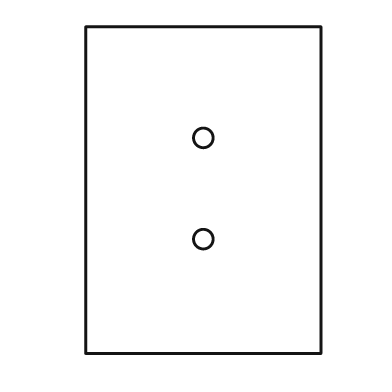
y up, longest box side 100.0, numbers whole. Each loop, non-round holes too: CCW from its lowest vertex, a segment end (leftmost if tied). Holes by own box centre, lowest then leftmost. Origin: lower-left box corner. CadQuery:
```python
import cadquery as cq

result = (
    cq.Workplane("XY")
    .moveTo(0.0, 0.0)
    .lineTo(72.0, 0.0)
    .lineTo(72.0, 100.0)
    .lineTo(0.0, 100.0)
    .close()
    .moveTo(36.0, 35.0)
    .circle(3.0)
    .moveTo(36.0, 66.0)
    .circle(3.0)
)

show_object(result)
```